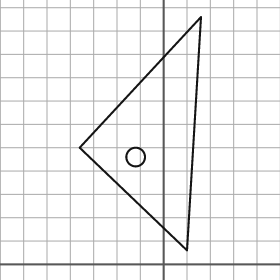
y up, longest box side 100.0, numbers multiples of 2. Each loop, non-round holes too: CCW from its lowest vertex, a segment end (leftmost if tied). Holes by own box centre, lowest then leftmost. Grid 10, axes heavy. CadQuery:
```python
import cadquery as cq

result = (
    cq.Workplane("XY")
    .moveTo(10.0, 6.0)
    .lineTo(16.0, 106.0)
    .lineTo(-36.0, 50.0)
    .close()
    .moveTo(-12.0, 46.0)
    .circle(4.0)
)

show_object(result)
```